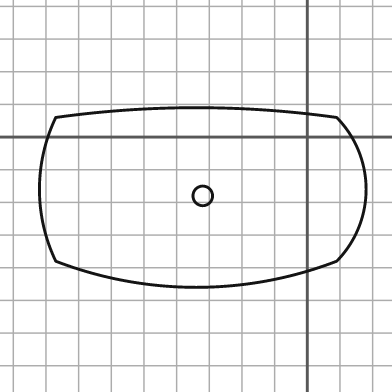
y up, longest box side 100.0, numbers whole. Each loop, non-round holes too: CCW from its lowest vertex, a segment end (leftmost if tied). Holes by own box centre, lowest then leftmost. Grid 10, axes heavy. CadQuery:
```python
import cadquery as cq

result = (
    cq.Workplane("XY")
    .moveTo(-77.0, -38.0)
    .threePointArc((-34.0, -46.0), (9.0, -38.0))
    .threePointArc((18.0, -16.0), (9.0, 6.0))
    .threePointArc((-34.0, 9.0), (-77.0, 6.0))
    .threePointArc((-82.0, -16.0), (-77.0, -38.0))
    .close()
    .moveTo(-32.0, -18.0)
    .circle(3.0)
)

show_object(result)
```